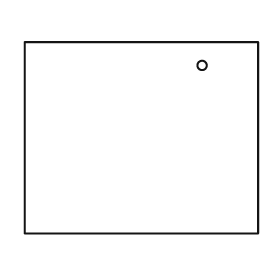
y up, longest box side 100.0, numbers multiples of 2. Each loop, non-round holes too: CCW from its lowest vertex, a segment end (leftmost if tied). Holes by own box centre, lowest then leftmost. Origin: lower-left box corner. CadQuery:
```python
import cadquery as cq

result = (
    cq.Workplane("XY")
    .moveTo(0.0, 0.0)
    .lineTo(100.0, 0.0)
    .lineTo(100.0, 82.0)
    .lineTo(0.0, 82.0)
    .close()
    .moveTo(76.0, 72.0)
    .circle(2.0)
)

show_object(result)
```